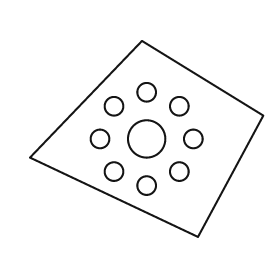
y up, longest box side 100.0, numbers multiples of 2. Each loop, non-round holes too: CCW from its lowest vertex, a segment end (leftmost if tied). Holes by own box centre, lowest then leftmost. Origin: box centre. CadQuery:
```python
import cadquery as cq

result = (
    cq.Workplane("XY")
    .moveTo(22.0, -42.0)
    .lineTo(50.0, 10.0)
    .lineTo(-2.0, 42.0)
    .lineTo(-50.0, -8.0)
    .close()
    .moveTo(0.0, -20.0)
    .circle(4.0)
    .moveTo(-14.0, -14.0)
    .circle(4.0)
    .moveTo(14.0, -14.0)
    .circle(4.0)
    .moveTo(-20.0, 0.0)
    .circle(4.0)
    .moveTo(0.0, 0.0)
    .circle(8.0)
    .moveTo(20.0, 0.0)
    .circle(4.0)
    .moveTo(-14.0, 14.0)
    .circle(4.0)
    .moveTo(14.0, 14.0)
    .circle(4.0)
    .moveTo(0.0, 20.0)
    .circle(4.0)
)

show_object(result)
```